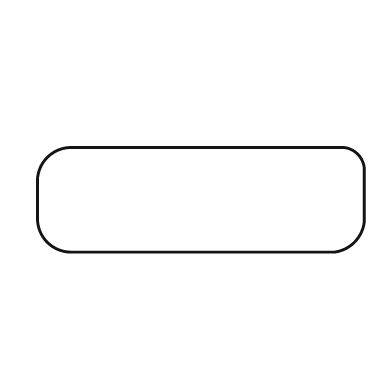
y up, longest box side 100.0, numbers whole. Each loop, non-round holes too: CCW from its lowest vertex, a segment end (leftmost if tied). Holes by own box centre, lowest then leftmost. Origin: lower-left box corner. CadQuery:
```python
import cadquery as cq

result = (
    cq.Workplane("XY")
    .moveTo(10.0, 0.0)
    .lineTo(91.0, 0.0)
    .threePointArc((97.0, 3.0), (100.0, 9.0))
    .lineTo(100.0, 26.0)
    .threePointArc((98.0, 30.0), (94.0, 32.0))
    .lineTo(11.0, 32.0)
    .threePointArc((3.0, 29.0), (0.0, 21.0))
    .lineTo(0.0, 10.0)
    .threePointArc((3.0, 3.0), (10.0, 0.0))
    .close()
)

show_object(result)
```